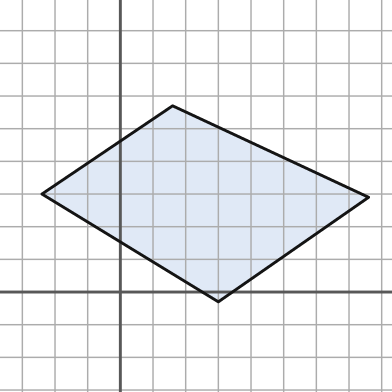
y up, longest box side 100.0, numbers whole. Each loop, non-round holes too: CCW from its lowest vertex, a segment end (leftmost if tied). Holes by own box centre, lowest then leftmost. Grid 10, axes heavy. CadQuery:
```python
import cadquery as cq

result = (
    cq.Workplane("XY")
    .moveTo(30.0, -3.0)
    .lineTo(76.0, 29.0)
    .lineTo(16.0, 57.0)
    .lineTo(-24.0, 30.0)
    .close()
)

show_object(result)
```